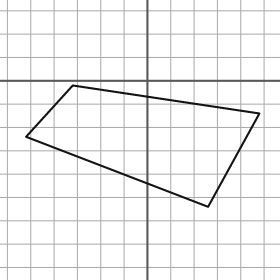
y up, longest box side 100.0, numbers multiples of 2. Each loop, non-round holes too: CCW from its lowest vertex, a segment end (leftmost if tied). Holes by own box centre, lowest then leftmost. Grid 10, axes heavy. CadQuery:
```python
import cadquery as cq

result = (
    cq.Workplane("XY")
    .moveTo(26.0, -54.0)
    .lineTo(48.0, -14.0)
    .lineTo(-32.0, -2.0)
    .lineTo(-52.0, -24.0)
    .close()
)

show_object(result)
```